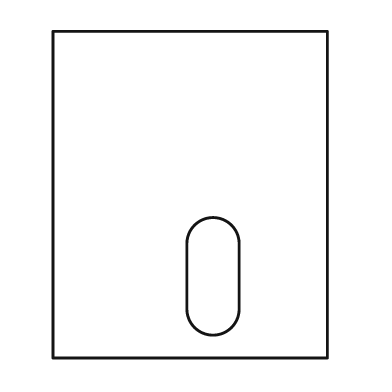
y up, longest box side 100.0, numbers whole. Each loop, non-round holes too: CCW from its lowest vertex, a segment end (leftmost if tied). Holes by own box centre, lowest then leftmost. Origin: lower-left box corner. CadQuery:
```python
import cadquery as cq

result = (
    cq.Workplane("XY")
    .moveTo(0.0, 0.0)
    .lineTo(84.0, 0.0)
    .lineTo(84.0, 100.0)
    .lineTo(0.0, 100.0)
    .close()
    .moveTo(41.0, 15.0)
    .threePointArc((49.0, 7.0), (57.0, 15.0))
    .lineTo(57.0, 35.0)
    .threePointArc((49.0, 43.0), (41.0, 35.0))
    .close()
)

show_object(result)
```